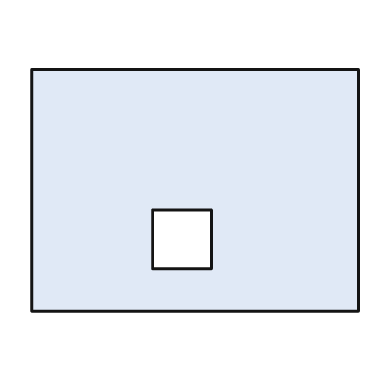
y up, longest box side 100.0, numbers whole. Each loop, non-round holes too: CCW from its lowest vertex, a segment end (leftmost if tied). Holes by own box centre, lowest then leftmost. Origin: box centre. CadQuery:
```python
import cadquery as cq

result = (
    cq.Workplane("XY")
    .moveTo(-50.0, -37.0)
    .lineTo(50.0, -37.0)
    .lineTo(50.0, 37.0)
    .lineTo(-50.0, 37.0)
    .close()
    .moveTo(-13.0, -24.0)
    .lineTo(5.0, -24.0)
    .lineTo(5.0, -6.0)
    .lineTo(-13.0, -6.0)
    .close()
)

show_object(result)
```